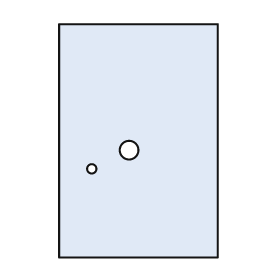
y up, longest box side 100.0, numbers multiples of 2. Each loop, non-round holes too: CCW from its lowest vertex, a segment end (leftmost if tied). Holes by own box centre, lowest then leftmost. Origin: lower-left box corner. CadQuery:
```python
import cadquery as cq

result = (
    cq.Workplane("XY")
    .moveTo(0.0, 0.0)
    .lineTo(68.0, 0.0)
    .lineTo(68.0, 100.0)
    .lineTo(0.0, 100.0)
    .close()
    .moveTo(14.0, 38.0)
    .circle(2.0)
    .moveTo(30.0, 46.0)
    .circle(4.0)
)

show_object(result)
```